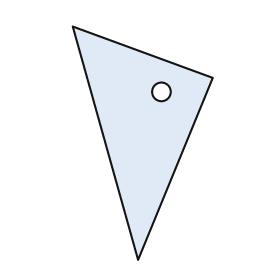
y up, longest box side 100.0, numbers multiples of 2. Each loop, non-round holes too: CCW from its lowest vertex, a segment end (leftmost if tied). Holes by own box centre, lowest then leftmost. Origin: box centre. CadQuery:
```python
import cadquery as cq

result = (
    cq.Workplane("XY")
    .moveTo(-2.0, -50.0)
    .lineTo(30.0, 28.0)
    .lineTo(-30.0, 50.0)
    .close()
    .moveTo(8.0, 22.0)
    .circle(4.0)
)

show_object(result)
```